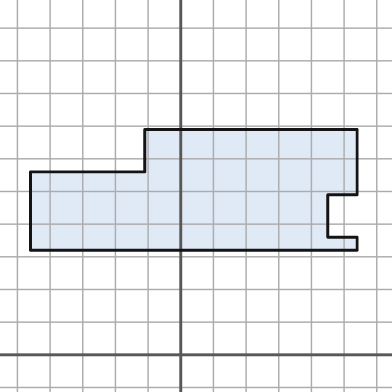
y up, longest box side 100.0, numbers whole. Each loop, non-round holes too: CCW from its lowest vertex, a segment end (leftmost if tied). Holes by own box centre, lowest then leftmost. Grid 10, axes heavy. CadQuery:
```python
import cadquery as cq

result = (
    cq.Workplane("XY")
    .moveTo(-46.0, 32.0)
    .lineTo(54.0, 32.0)
    .lineTo(54.0, 36.0)
    .lineTo(45.0, 36.0)
    .lineTo(45.0, 49.0)
    .lineTo(54.0, 49.0)
    .lineTo(54.0, 69.0)
    .lineTo(-11.0, 69.0)
    .lineTo(-11.0, 56.0)
    .lineTo(-46.0, 56.0)
    .close()
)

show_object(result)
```